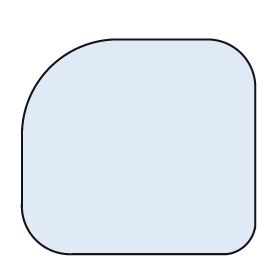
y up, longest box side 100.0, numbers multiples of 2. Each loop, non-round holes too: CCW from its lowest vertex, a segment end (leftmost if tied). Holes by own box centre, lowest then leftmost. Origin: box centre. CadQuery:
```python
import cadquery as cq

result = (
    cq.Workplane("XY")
    .moveTo(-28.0, -46.0)
    .lineTo(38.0, -46.0)
    .threePointArc((46.0, -42.0), (50.0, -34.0))
    .lineTo(50.0, 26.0)
    .threePointArc((44.0, 40.0), (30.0, 46.0))
    .lineTo(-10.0, 46.0)
    .threePointArc((-38.0, 34.0), (-50.0, 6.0))
    .lineTo(-50.0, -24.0)
    .threePointArc((-44.0, -40.0), (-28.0, -46.0))
    .close()
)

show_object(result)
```